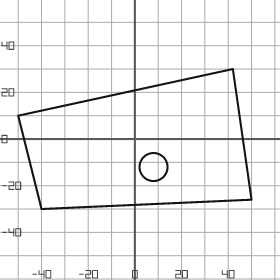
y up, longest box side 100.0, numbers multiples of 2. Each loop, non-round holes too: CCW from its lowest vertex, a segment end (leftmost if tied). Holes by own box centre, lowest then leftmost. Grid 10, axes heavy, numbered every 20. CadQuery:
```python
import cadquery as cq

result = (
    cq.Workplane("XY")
    .moveTo(-40.0, -30.0)
    .lineTo(50.0, -26.0)
    .lineTo(42.0, 30.0)
    .lineTo(-50.0, 10.0)
    .close()
    .moveTo(8.0, -12.0)
    .circle(6.0)
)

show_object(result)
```